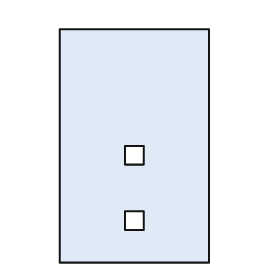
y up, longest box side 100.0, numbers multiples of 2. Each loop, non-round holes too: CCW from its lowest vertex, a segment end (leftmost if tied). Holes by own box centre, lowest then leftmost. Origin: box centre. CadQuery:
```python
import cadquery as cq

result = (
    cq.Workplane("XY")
    .moveTo(-32.0, -50.0)
    .lineTo(32.0, -50.0)
    .lineTo(32.0, 50.0)
    .lineTo(-32.0, 50.0)
    .close()
    .moveTo(-4.0, -36.0)
    .lineTo(4.0, -36.0)
    .lineTo(4.0, -28.0)
    .lineTo(-4.0, -28.0)
    .close()
    .moveTo(-4.0, -8.0)
    .lineTo(4.0, -8.0)
    .lineTo(4.0, 0.0)
    .lineTo(-4.0, 0.0)
    .close()
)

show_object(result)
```